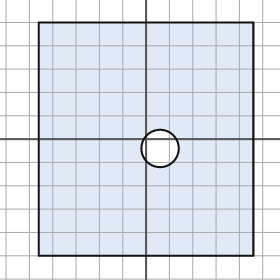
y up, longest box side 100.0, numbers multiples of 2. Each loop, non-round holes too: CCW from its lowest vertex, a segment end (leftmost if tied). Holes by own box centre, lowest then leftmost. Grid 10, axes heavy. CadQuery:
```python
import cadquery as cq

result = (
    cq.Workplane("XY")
    .moveTo(-46.0, -50.0)
    .lineTo(46.0, -50.0)
    .lineTo(46.0, 50.0)
    .lineTo(-46.0, 50.0)
    .close()
    .moveTo(6.0, -4.0)
    .circle(8.0)
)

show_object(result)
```